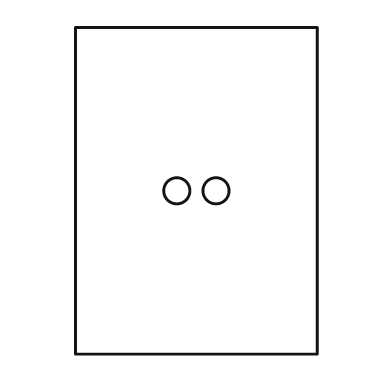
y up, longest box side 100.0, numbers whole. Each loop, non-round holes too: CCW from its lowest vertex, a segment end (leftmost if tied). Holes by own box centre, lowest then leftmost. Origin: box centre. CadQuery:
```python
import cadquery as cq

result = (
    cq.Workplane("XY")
    .moveTo(-37.0, -50.0)
    .lineTo(37.0, -50.0)
    .lineTo(37.0, 50.0)
    .lineTo(-37.0, 50.0)
    .close()
    .moveTo(-6.0, 0.0)
    .circle(4.0)
    .moveTo(6.0, 0.0)
    .circle(4.0)
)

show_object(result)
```